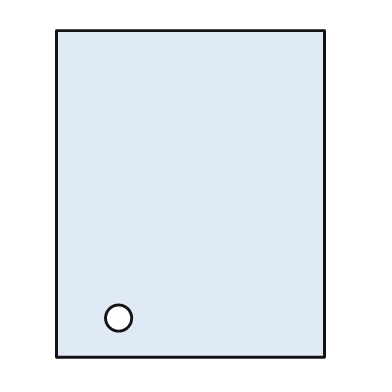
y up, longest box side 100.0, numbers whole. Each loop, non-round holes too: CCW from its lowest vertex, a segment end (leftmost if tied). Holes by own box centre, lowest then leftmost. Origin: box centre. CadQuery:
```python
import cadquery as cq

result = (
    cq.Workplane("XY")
    .moveTo(-41.0, -50.0)
    .lineTo(41.0, -50.0)
    .lineTo(41.0, 50.0)
    .lineTo(-41.0, 50.0)
    .close()
    .moveTo(-22.0, -38.0)
    .circle(4.0)
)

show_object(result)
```